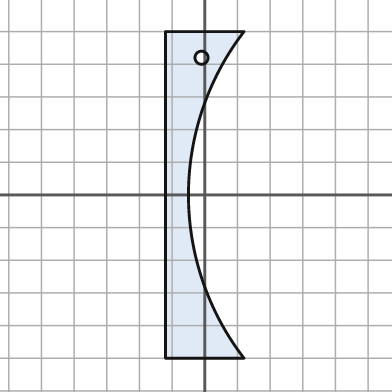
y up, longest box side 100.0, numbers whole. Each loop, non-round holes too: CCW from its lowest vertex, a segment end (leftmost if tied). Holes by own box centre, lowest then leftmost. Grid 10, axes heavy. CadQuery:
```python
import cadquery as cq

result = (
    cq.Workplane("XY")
    .moveTo(-12.0, -50.0)
    .lineTo(12.0, -50.0)
    .threePointArc((-5.0, 0.0), (12.0, 50.0))
    .lineTo(-12.0, 50.0)
    .close()
    .moveTo(-1.0, 42.0)
    .circle(2.0)
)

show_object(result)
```